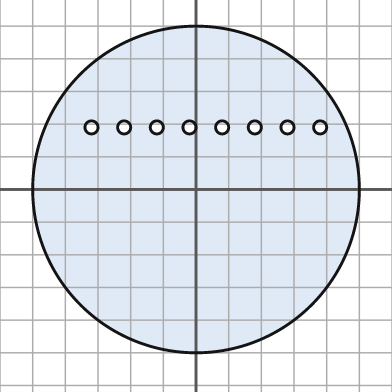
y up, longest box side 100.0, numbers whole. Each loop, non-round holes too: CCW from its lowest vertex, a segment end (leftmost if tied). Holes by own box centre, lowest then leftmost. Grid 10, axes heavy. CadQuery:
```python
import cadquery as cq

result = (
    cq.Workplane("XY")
    .moveTo(0.0, 0.0)
    .circle(50.0)
    .moveTo(-32.0, 19.0)
    .circle(2.0)
    .moveTo(-22.0, 19.0)
    .circle(2.0)
    .moveTo(-12.0, 19.0)
    .circle(2.0)
    .moveTo(-2.0, 19.0)
    .circle(2.0)
    .moveTo(8.0, 19.0)
    .circle(2.0)
    .moveTo(18.0, 19.0)
    .circle(2.0)
    .moveTo(28.0, 19.0)
    .circle(2.0)
    .moveTo(38.0, 19.0)
    .circle(2.0)
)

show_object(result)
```